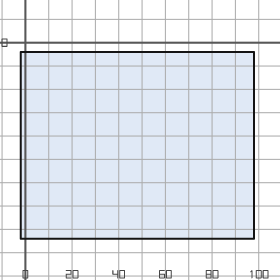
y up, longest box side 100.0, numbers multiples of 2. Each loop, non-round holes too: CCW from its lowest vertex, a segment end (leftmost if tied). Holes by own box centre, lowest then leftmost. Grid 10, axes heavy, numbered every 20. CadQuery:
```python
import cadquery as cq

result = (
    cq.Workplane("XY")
    .moveTo(-2.0, -84.0)
    .lineTo(98.0, -84.0)
    .lineTo(98.0, -4.0)
    .lineTo(-2.0, -4.0)
    .close()
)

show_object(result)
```